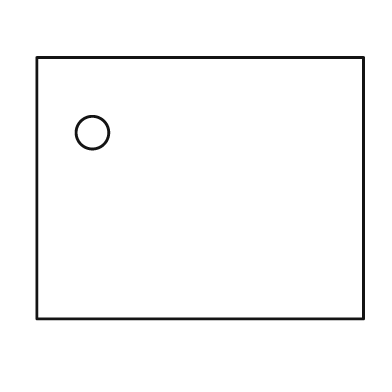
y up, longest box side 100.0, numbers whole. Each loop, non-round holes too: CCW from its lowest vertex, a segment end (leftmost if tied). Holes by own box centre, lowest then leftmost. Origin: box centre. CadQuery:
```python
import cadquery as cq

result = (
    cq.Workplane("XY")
    .moveTo(-50.0, -40.0)
    .lineTo(50.0, -40.0)
    .lineTo(50.0, 40.0)
    .lineTo(-50.0, 40.0)
    .close()
    .moveTo(-33.0, 17.0)
    .circle(5.0)
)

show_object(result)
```